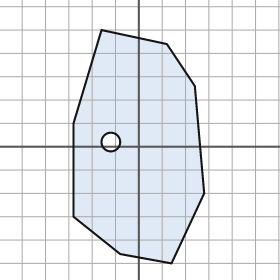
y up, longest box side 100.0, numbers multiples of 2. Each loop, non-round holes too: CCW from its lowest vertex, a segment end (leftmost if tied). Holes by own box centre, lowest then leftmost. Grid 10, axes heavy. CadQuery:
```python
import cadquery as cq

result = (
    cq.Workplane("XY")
    .moveTo(14.0, -50.0)
    .lineTo(28.0, -20.0)
    .lineTo(24.0, 26.0)
    .lineTo(12.0, 44.0)
    .lineTo(-16.0, 50.0)
    .lineTo(-28.0, 10.0)
    .lineTo(-28.0, -30.0)
    .lineTo(-8.0, -46.0)
    .close()
    .moveTo(-12.0, 2.0)
    .circle(4.0)
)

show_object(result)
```